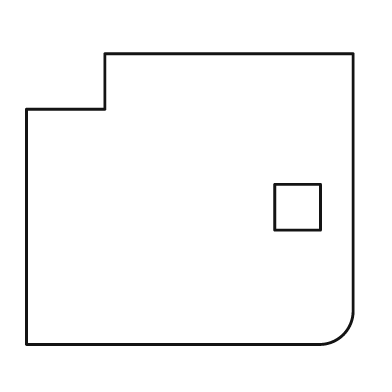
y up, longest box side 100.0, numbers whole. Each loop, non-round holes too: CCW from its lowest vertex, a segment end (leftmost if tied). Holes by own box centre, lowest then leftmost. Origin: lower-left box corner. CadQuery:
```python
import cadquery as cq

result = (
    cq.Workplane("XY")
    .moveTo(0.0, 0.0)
    .lineTo(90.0, 0.0)
    .threePointArc((97.0, 3.0), (100.0, 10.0))
    .lineTo(100.0, 89.0)
    .lineTo(24.0, 89.0)
    .lineTo(24.0, 72.0)
    .lineTo(0.0, 72.0)
    .close()
    .moveTo(76.0, 35.0)
    .lineTo(90.0, 35.0)
    .lineTo(90.0, 49.0)
    .lineTo(76.0, 49.0)
    .close()
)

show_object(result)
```